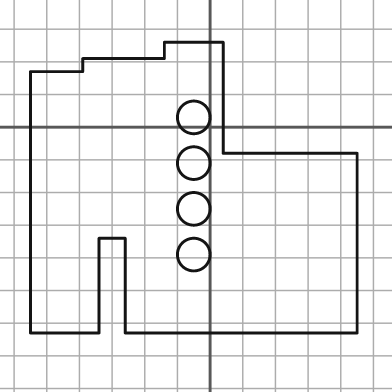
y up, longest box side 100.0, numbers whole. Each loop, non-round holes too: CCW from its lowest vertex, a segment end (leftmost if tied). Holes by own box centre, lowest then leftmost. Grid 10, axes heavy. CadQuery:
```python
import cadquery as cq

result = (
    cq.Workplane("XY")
    .moveTo(-55.0, -63.0)
    .lineTo(-34.0, -63.0)
    .lineTo(-34.0, -34.0)
    .lineTo(-26.0, -34.0)
    .lineTo(-26.0, -63.0)
    .lineTo(45.0, -63.0)
    .lineTo(45.0, -8.0)
    .lineTo(4.0, -8.0)
    .lineTo(4.0, 26.0)
    .lineTo(-14.0, 26.0)
    .lineTo(-14.0, 21.0)
    .lineTo(-39.0, 21.0)
    .lineTo(-39.0, 17.0)
    .lineTo(-55.0, 17.0)
    .close()
    .moveTo(-5.0, -39.0)
    .circle(5.0)
    .moveTo(-5.0, -25.0)
    .circle(5.0)
    .moveTo(-5.0, -11.0)
    .circle(5.0)
    .moveTo(-5.0, 3.0)
    .circle(5.0)
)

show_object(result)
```